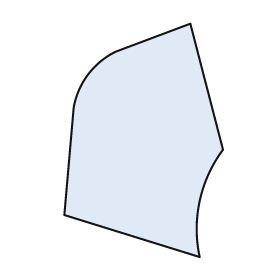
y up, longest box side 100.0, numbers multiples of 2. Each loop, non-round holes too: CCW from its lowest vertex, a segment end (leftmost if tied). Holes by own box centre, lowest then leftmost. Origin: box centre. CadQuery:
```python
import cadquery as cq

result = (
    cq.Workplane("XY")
    .moveTo(24.0, -50.0)
    .threePointArc((24.0, -26.0), (34.0, -4.0))
    .lineTo(20.0, 50.0)
    .lineTo(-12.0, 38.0)
    .threePointArc((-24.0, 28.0), (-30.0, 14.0))
    .lineTo(-34.0, -32.0)
    .close()
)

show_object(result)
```